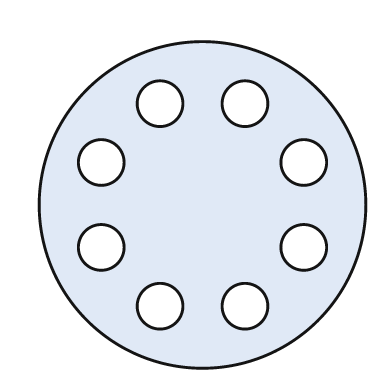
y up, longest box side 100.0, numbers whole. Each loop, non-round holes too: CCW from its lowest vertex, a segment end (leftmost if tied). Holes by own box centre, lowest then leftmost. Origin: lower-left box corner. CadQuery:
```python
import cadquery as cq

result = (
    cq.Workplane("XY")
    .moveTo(50.0, 50.0)
    .circle(50.0)
    .moveTo(37.0, 19.0)
    .circle(7.0)
    .moveTo(63.0, 19.0)
    .circle(7.0)
    .moveTo(19.0, 37.0)
    .circle(7.0)
    .moveTo(81.0, 37.0)
    .circle(7.0)
    .moveTo(19.0, 63.0)
    .circle(7.0)
    .moveTo(81.0, 63.0)
    .circle(7.0)
    .moveTo(37.0, 81.0)
    .circle(7.0)
    .moveTo(63.0, 81.0)
    .circle(7.0)
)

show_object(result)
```